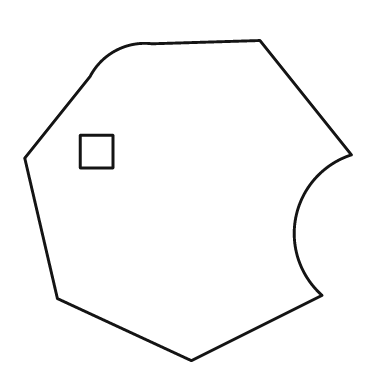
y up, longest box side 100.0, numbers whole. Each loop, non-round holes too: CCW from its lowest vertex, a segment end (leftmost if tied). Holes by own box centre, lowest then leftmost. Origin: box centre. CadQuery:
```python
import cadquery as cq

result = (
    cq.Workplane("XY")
    .moveTo(1.0, -49.0)
    .lineTo(41.0, -29.0)
    .threePointArc((33.0, -5.0), (50.0, 14.0))
    .lineTo(22.0, 49.0)
    .lineTo(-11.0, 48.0)
    .threePointArc((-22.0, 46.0), (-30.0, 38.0))
    .lineTo(-50.0, 13.0)
    .lineTo(-40.0, -30.0)
    .close()
    .moveTo(-33.0, 10.0)
    .lineTo(-23.0, 10.0)
    .lineTo(-23.0, 20.0)
    .lineTo(-33.0, 20.0)
    .close()
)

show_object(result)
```